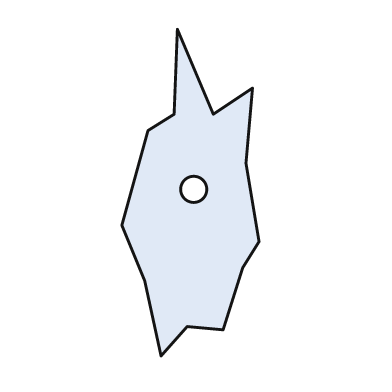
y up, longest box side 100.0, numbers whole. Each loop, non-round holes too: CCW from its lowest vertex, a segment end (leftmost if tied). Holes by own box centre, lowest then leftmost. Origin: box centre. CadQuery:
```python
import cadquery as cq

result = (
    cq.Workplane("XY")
    .moveTo(-9.0, -50.0)
    .lineTo(-1.0, -41.0)
    .lineTo(10.0, -42.0)
    .lineTo(16.0, -23.0)
    .lineTo(21.0, -15.0)
    .lineTo(17.0, 9.0)
    .lineTo(19.0, 32.0)
    .lineTo(7.0, 24.0)
    .lineTo(-4.0, 50.0)
    .lineTo(-5.0, 24.0)
    .lineTo(-13.0, 19.0)
    .lineTo(-21.0, -10.0)
    .lineTo(-14.0, -27.0)
    .close()
    .moveTo(1.0, 1.0)
    .circle(4.0)
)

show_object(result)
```